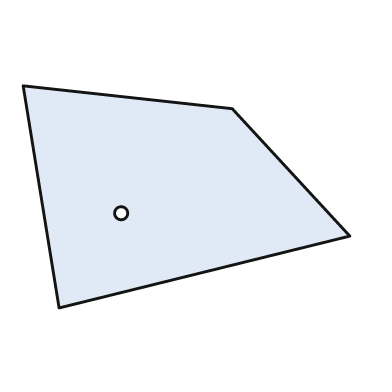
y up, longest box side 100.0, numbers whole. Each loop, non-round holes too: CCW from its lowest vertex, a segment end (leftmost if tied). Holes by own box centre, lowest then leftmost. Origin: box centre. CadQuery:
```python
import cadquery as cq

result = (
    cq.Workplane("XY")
    .moveTo(-39.0, -34.0)
    .lineTo(50.0, -12.0)
    .lineTo(14.0, 27.0)
    .lineTo(-50.0, 34.0)
    .close()
    .moveTo(-20.0, -5.0)
    .circle(2.0)
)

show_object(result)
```